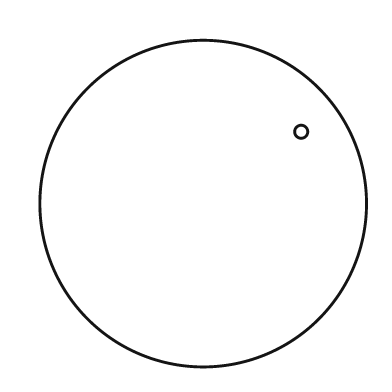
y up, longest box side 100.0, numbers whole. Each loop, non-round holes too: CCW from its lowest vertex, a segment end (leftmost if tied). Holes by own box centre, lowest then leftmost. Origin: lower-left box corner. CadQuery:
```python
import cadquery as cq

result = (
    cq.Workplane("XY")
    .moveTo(50.0, 50.0)
    .circle(50.0)
    .moveTo(80.0, 72.0)
    .circle(2.0)
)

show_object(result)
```